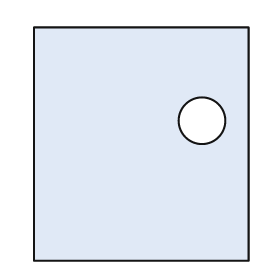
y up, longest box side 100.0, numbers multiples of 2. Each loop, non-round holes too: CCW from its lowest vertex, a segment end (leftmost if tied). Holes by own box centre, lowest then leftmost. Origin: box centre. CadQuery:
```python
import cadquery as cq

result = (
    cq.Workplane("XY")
    .moveTo(-46.0, -50.0)
    .lineTo(46.0, -50.0)
    .lineTo(46.0, 50.0)
    .lineTo(-46.0, 50.0)
    .close()
    .moveTo(26.0, 10.0)
    .circle(10.0)
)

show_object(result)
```